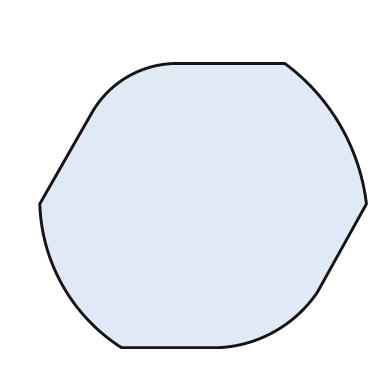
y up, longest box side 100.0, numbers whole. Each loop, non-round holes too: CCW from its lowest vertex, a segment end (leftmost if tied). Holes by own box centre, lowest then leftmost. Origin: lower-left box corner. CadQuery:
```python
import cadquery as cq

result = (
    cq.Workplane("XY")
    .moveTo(25.0, 0.0)
    .lineTo(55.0, 0.0)
    .threePointArc((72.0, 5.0), (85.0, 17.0))
    .lineTo(100.0, 44.0)
    .threePointArc((92.0, 68.0), (75.0, 87.0))
    .lineTo(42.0, 87.0)
    .threePointArc((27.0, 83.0), (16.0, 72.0))
    .lineTo(0.0, 44.0)
    .threePointArc((7.0, 19.0), (25.0, 0.0))
    .close()
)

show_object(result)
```